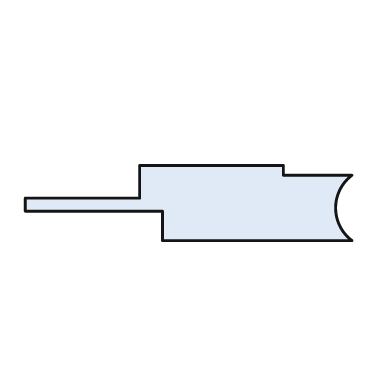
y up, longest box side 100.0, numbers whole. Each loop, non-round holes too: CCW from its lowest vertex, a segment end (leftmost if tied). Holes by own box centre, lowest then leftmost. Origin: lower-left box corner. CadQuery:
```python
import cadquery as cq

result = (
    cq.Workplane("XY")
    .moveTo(42.0, 0.0)
    .lineTo(100.0, 0.0)
    .threePointArc((95.0, 10.0), (100.0, 20.0))
    .lineTo(79.0, 20.0)
    .lineTo(79.0, 23.0)
    .lineTo(35.0, 23.0)
    .lineTo(35.0, 13.0)
    .lineTo(0.0, 13.0)
    .lineTo(0.0, 9.0)
    .lineTo(42.0, 9.0)
    .close()
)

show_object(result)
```